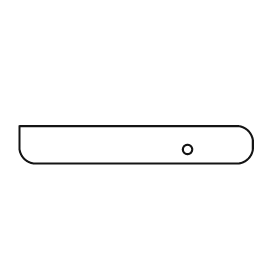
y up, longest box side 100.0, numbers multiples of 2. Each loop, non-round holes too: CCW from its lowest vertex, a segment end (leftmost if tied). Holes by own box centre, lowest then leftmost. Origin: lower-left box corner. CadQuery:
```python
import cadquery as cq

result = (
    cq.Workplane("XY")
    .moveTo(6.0, 0.0)
    .lineTo(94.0, 0.0)
    .threePointArc((98.0, 2.0), (100.0, 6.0))
    .lineTo(100.0, 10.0)
    .threePointArc((98.0, 14.0), (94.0, 16.0))
    .lineTo(0.0, 16.0)
    .lineTo(0.0, 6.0)
    .threePointArc((2.0, 2.0), (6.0, 0.0))
    .close()
    .moveTo(72.0, 6.0)
    .circle(2.0)
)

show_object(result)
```